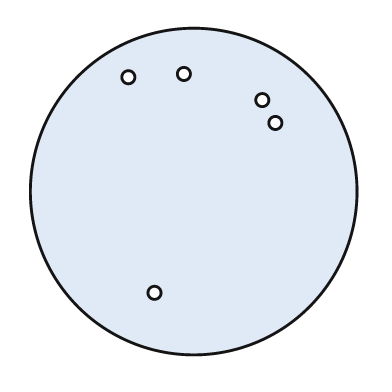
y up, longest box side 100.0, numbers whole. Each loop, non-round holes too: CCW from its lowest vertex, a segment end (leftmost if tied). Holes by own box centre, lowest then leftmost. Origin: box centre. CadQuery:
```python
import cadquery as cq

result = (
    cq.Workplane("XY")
    .moveTo(0.0, 0.0)
    .circle(50.0)
    .moveTo(-12.0, -31.0)
    .circle(2.0)
    .moveTo(25.0, 21.0)
    .circle(2.0)
    .moveTo(21.0, 28.0)
    .circle(2.0)
    .moveTo(-20.0, 35.0)
    .circle(2.0)
    .moveTo(-3.0, 36.0)
    .circle(2.0)
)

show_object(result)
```